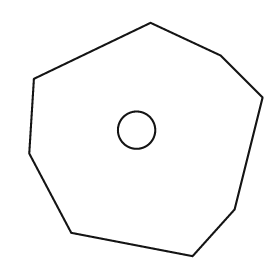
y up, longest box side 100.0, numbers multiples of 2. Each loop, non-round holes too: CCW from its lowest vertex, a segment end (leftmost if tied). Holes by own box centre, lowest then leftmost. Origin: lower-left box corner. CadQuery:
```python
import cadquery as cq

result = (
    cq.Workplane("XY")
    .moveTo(70.0, 0.0)
    .lineTo(88.0, 20.0)
    .lineTo(100.0, 68.0)
    .lineTo(82.0, 86.0)
    .lineTo(52.0, 100.0)
    .lineTo(2.0, 76.0)
    .lineTo(0.0, 44.0)
    .lineTo(18.0, 10.0)
    .close()
    .moveTo(46.0, 54.0)
    .circle(8.0)
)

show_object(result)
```